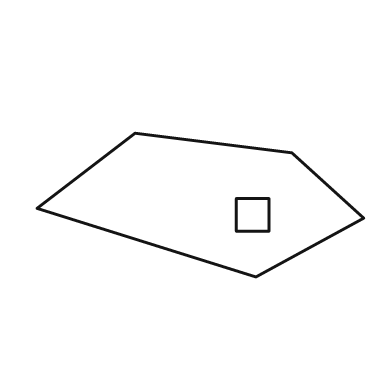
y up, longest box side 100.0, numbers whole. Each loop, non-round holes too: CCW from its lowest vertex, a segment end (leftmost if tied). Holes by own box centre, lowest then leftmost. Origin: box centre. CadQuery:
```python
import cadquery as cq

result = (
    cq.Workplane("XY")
    .moveTo(17.0, -22.0)
    .lineTo(50.0, -4.0)
    .lineTo(28.0, 16.0)
    .lineTo(-20.0, 22.0)
    .lineTo(-50.0, -1.0)
    .close()
    .moveTo(11.0, -8.0)
    .lineTo(21.0, -8.0)
    .lineTo(21.0, 2.0)
    .lineTo(11.0, 2.0)
    .close()
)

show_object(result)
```